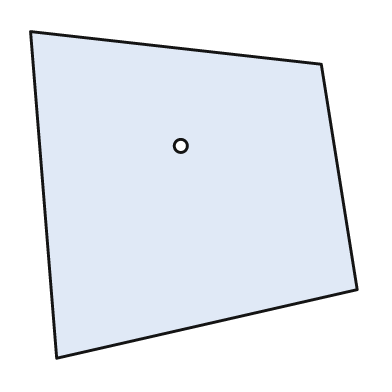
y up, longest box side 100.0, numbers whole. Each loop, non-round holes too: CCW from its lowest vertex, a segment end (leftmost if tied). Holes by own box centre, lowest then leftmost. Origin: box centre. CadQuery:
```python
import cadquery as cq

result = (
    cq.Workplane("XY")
    .moveTo(-42.0, -50.0)
    .lineTo(50.0, -29.0)
    .lineTo(39.0, 40.0)
    .lineTo(-50.0, 50.0)
    .close()
    .moveTo(-4.0, 15.0)
    .circle(2.0)
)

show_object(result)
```